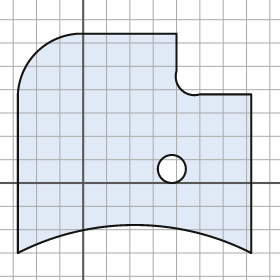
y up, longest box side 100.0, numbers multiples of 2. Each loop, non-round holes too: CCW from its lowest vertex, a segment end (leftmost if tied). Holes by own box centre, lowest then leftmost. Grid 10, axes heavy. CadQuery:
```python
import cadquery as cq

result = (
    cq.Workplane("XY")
    .moveTo(-28.0, -30.0)
    .threePointArc((22.0, -18.0), (72.0, -30.0))
    .lineTo(72.0, 38.0)
    .lineTo(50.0, 38.0)
    .threePointArc((42.0, 40.0), (40.0, 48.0))
    .lineTo(40.0, 64.0)
    .lineTo(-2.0, 64.0)
    .threePointArc((-20.0, 56.0), (-28.0, 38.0))
    .close()
    .moveTo(38.0, 6.0)
    .circle(6.0)
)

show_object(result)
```